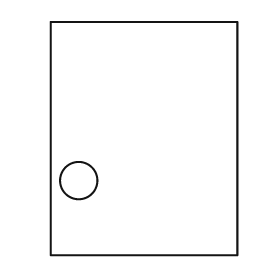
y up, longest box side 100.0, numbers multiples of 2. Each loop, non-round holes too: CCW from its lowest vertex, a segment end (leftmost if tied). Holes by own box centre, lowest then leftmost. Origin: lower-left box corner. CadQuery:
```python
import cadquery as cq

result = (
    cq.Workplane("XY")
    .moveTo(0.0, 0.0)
    .lineTo(80.0, 0.0)
    .lineTo(80.0, 100.0)
    .lineTo(0.0, 100.0)
    .close()
    .moveTo(12.0, 32.0)
    .circle(8.0)
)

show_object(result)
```